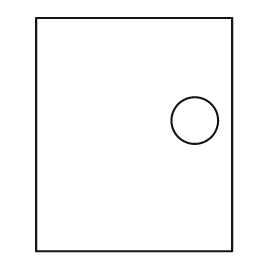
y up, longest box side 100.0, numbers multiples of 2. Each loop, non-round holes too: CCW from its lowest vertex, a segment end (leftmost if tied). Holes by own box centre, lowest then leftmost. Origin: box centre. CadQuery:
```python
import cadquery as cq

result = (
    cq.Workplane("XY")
    .moveTo(-42.0, -50.0)
    .lineTo(42.0, -50.0)
    .lineTo(42.0, 50.0)
    .lineTo(-42.0, 50.0)
    .close()
    .moveTo(26.0, 6.0)
    .circle(10.0)
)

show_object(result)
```